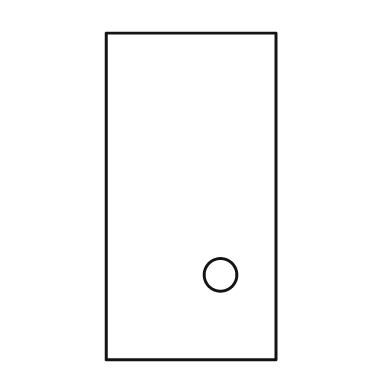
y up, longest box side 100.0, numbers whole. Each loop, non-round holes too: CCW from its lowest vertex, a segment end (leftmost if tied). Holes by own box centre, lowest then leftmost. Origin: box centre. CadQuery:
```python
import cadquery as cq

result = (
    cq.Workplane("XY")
    .moveTo(-26.0, -50.0)
    .lineTo(26.0, -50.0)
    .lineTo(26.0, 50.0)
    .lineTo(-26.0, 50.0)
    .close()
    .moveTo(9.0, -24.0)
    .circle(5.0)
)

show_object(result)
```